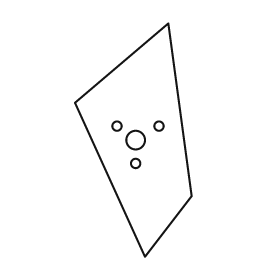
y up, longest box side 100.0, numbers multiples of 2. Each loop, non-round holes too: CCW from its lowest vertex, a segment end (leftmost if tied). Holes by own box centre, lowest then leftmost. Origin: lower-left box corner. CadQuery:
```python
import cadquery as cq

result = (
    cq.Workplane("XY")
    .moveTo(30.0, 0.0)
    .lineTo(50.0, 26.0)
    .lineTo(40.0, 100.0)
    .lineTo(0.0, 66.0)
    .close()
    .moveTo(26.0, 40.0)
    .circle(2.0)
    .moveTo(26.0, 50.0)
    .circle(4.0)
    .moveTo(18.0, 56.0)
    .circle(2.0)
    .moveTo(36.0, 56.0)
    .circle(2.0)
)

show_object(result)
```